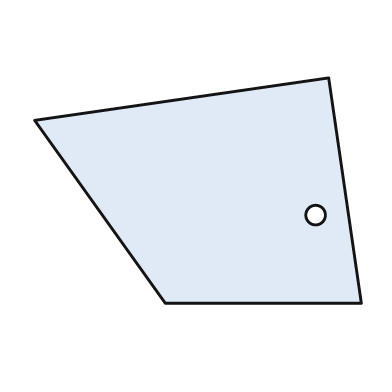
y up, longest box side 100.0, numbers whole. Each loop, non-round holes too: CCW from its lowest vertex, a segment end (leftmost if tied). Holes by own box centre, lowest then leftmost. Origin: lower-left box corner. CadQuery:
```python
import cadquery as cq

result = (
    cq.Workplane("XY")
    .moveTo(40.0, 0.0)
    .lineTo(100.0, 0.0)
    .lineTo(90.0, 69.0)
    .lineTo(0.0, 56.0)
    .close()
    .moveTo(86.0, 27.0)
    .circle(3.0)
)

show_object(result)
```